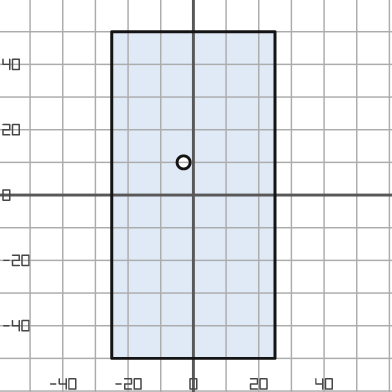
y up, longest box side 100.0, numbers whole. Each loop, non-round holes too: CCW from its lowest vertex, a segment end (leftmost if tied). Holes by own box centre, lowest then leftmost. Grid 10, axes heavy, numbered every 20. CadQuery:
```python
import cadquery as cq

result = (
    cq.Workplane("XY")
    .moveTo(-25.0, -50.0)
    .lineTo(25.0, -50.0)
    .lineTo(25.0, 50.0)
    .lineTo(-25.0, 50.0)
    .close()
    .moveTo(-3.0, 10.0)
    .circle(2.0)
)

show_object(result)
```